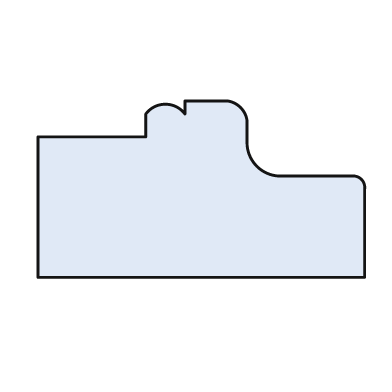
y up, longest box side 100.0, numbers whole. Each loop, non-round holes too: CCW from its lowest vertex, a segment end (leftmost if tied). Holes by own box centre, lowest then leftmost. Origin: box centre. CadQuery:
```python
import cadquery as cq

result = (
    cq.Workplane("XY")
    .moveTo(-50.0, -27.0)
    .lineTo(50.0, -27.0)
    .lineTo(50.0, 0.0)
    .threePointArc((49.0, 3.0), (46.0, 4.0))
    .lineTo(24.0, 4.0)
    .threePointArc((17.0, 7.0), (14.0, 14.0))
    .lineTo(14.0, 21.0)
    .threePointArc((12.0, 25.0), (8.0, 27.0))
    .lineTo(-5.0, 27.0)
    .lineTo(-5.0, 23.0)
    .threePointArc((-11.0, 26.0), (-17.0, 23.0))
    .lineTo(-17.0, 16.0)
    .lineTo(-50.0, 16.0)
    .close()
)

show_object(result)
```